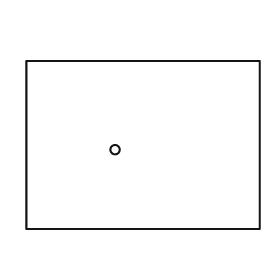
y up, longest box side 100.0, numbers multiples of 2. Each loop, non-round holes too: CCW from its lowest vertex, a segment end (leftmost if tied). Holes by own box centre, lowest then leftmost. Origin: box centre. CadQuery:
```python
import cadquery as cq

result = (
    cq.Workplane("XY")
    .moveTo(-50.0, -36.0)
    .lineTo(50.0, -36.0)
    .lineTo(50.0, 36.0)
    .lineTo(-50.0, 36.0)
    .close()
    .moveTo(-12.0, -2.0)
    .circle(2.0)
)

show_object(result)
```